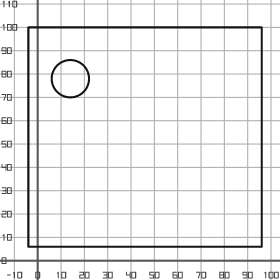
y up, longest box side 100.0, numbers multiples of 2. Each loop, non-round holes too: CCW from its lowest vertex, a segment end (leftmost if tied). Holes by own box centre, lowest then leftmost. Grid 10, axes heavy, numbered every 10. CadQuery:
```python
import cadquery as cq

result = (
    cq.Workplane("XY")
    .moveTo(-4.0, 6.0)
    .lineTo(96.0, 6.0)
    .lineTo(96.0, 100.0)
    .lineTo(-4.0, 100.0)
    .close()
    .moveTo(14.0, 78.0)
    .circle(8.0)
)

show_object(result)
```